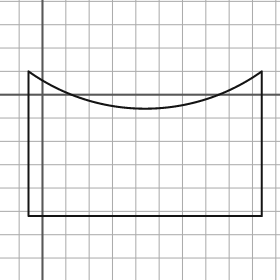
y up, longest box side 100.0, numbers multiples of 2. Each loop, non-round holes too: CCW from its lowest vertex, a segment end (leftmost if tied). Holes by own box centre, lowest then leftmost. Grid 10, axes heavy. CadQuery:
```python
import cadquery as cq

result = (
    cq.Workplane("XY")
    .moveTo(-6.0, -52.0)
    .lineTo(94.0, -52.0)
    .lineTo(94.0, 10.0)
    .threePointArc((44.0, -6.0), (-6.0, 10.0))
    .close()
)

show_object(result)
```